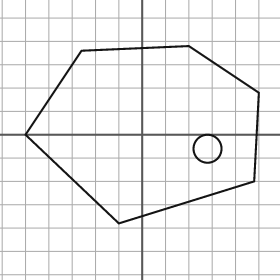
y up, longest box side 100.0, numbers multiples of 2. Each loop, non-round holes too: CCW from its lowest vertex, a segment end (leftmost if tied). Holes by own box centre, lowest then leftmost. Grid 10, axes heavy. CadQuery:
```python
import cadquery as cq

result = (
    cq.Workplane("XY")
    .moveTo(-10.0, -38.0)
    .lineTo(48.0, -20.0)
    .lineTo(50.0, 18.0)
    .lineTo(20.0, 38.0)
    .lineTo(-26.0, 36.0)
    .lineTo(-50.0, 0.0)
    .close()
    .moveTo(28.0, -6.0)
    .circle(6.0)
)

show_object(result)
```